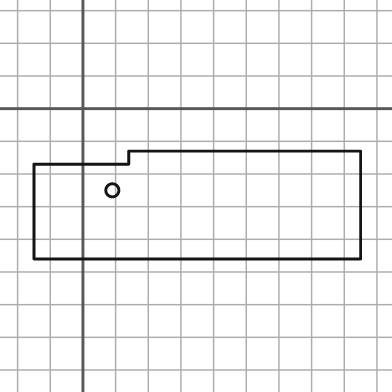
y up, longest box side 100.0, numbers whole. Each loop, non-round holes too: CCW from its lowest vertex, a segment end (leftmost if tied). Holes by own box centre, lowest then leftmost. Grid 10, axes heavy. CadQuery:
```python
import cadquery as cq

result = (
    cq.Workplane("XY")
    .moveTo(-15.0, -46.0)
    .lineTo(85.0, -46.0)
    .lineTo(85.0, -13.0)
    .lineTo(14.0, -13.0)
    .lineTo(14.0, -17.0)
    .lineTo(-15.0, -17.0)
    .close()
    .moveTo(9.0, -25.0)
    .circle(2.0)
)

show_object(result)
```